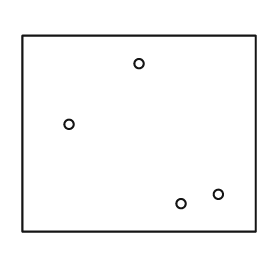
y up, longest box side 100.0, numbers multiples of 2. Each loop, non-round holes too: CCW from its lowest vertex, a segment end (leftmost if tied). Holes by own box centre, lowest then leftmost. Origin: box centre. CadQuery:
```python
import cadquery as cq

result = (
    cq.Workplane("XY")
    .moveTo(-50.0, -42.0)
    .lineTo(50.0, -42.0)
    .lineTo(50.0, 42.0)
    .lineTo(-50.0, 42.0)
    .close()
    .moveTo(18.0, -30.0)
    .circle(2.0)
    .moveTo(34.0, -26.0)
    .circle(2.0)
    .moveTo(-30.0, 4.0)
    .circle(2.0)
    .moveTo(0.0, 30.0)
    .circle(2.0)
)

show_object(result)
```